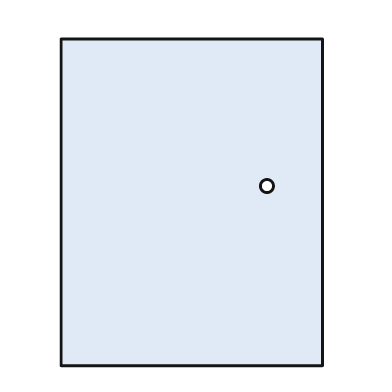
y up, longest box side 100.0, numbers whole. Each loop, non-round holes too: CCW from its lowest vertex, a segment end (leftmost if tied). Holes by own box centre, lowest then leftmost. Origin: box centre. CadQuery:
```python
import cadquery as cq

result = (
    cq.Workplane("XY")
    .moveTo(-40.0, -50.0)
    .lineTo(40.0, -50.0)
    .lineTo(40.0, 50.0)
    .lineTo(-40.0, 50.0)
    .close()
    .moveTo(23.0, 5.0)
    .circle(2.0)
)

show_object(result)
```